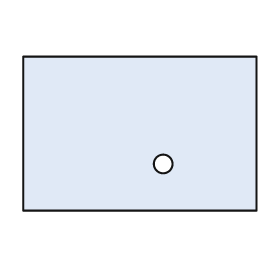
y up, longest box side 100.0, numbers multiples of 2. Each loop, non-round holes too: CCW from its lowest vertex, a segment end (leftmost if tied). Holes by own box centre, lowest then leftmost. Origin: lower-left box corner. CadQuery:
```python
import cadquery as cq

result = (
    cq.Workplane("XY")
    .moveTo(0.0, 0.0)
    .lineTo(100.0, 0.0)
    .lineTo(100.0, 66.0)
    .lineTo(0.0, 66.0)
    .close()
    .moveTo(60.0, 20.0)
    .circle(4.0)
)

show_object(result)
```